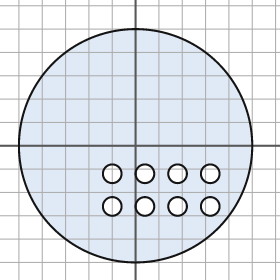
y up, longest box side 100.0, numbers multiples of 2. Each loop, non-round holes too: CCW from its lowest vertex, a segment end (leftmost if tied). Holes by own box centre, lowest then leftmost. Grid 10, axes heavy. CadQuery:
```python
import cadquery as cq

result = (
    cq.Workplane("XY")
    .moveTo(0.0, 0.0)
    .circle(50.0)
    .moveTo(-10.0, -26.0)
    .circle(4.0)
    .moveTo(4.0, -26.0)
    .circle(4.0)
    .moveTo(18.0, -26.0)
    .circle(4.0)
    .moveTo(32.0, -26.0)
    .circle(4.0)
    .moveTo(-10.0, -12.0)
    .circle(4.0)
    .moveTo(4.0, -12.0)
    .circle(4.0)
    .moveTo(18.0, -12.0)
    .circle(4.0)
    .moveTo(32.0, -12.0)
    .circle(4.0)
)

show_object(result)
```